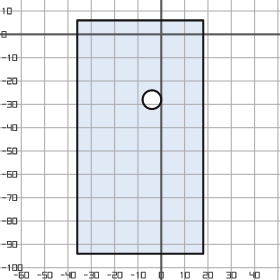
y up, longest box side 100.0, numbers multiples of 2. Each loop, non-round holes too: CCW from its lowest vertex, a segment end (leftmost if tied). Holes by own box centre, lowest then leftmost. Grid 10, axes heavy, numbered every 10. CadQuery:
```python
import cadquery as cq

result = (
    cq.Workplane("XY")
    .moveTo(-36.0, -94.0)
    .lineTo(18.0, -94.0)
    .lineTo(18.0, 6.0)
    .lineTo(-36.0, 6.0)
    .close()
    .moveTo(-4.0, -28.0)
    .circle(4.0)
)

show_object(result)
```